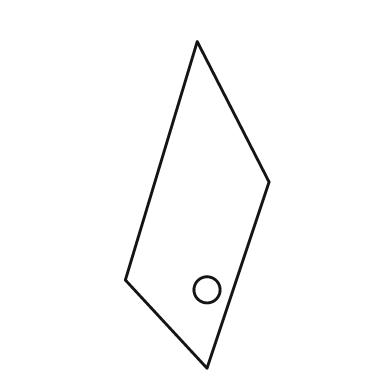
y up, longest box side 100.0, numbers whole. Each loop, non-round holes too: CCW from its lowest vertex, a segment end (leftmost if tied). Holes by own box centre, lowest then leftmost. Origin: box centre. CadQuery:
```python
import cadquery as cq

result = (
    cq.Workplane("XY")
    .moveTo(3.0, -50.0)
    .lineTo(22.0, 7.0)
    .lineTo(0.0, 50.0)
    .lineTo(-22.0, -23.0)
    .close()
    .moveTo(3.0, -26.0)
    .circle(4.0)
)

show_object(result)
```